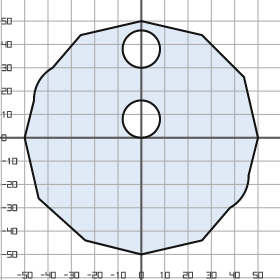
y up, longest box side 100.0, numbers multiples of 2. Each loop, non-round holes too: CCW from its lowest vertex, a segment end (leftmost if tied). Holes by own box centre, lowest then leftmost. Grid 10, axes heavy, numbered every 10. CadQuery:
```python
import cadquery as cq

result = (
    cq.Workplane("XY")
    .moveTo(0.0, -50.0)
    .lineTo(26.0, -44.0)
    .lineTo(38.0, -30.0)
    .threePointArc((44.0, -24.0), (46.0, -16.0))
    .lineTo(50.0, 0.0)
    .lineTo(44.0, 26.0)
    .lineTo(26.0, 44.0)
    .lineTo(0.0, 50.0)
    .lineTo(-26.0, 44.0)
    .lineTo(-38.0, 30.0)
    .threePointArc((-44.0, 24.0), (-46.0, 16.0))
    .lineTo(-50.0, 0.0)
    .lineTo(-44.0, -26.0)
    .lineTo(-24.0, -44.0)
    .close()
    .moveTo(0.0, 8.0)
    .circle(8.0)
    .moveTo(0.0, 38.0)
    .circle(8.0)
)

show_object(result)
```